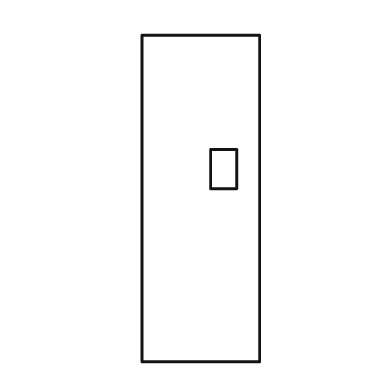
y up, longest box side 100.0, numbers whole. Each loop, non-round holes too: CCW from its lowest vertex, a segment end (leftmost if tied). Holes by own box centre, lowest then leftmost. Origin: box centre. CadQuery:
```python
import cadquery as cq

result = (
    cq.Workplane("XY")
    .moveTo(-18.0, -50.0)
    .lineTo(18.0, -50.0)
    .lineTo(18.0, 50.0)
    .lineTo(-18.0, 50.0)
    .close()
    .moveTo(3.0, 3.0)
    .lineTo(11.0, 3.0)
    .lineTo(11.0, 15.0)
    .lineTo(3.0, 15.0)
    .close()
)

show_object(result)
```